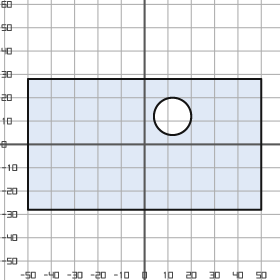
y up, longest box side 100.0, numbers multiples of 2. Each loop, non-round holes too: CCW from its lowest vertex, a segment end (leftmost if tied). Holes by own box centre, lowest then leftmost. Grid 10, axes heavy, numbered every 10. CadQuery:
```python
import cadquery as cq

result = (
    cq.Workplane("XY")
    .moveTo(-50.0, -28.0)
    .lineTo(50.0, -28.0)
    .lineTo(50.0, 28.0)
    .lineTo(-50.0, 28.0)
    .close()
    .moveTo(12.0, 12.0)
    .circle(8.0)
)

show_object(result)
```